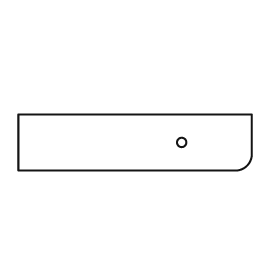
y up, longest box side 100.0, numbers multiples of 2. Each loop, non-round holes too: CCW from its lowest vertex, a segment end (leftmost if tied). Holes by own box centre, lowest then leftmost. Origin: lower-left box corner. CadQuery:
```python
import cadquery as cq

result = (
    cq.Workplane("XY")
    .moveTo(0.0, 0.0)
    .lineTo(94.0, 0.0)
    .threePointArc((98.0, 2.0), (100.0, 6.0))
    .lineTo(100.0, 24.0)
    .lineTo(0.0, 24.0)
    .close()
    .moveTo(70.0, 12.0)
    .circle(2.0)
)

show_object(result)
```